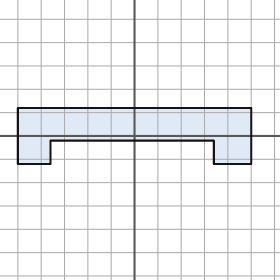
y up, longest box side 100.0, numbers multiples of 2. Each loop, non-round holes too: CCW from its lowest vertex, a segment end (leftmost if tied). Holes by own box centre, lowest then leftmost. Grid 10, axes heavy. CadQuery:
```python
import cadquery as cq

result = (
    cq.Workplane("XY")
    .moveTo(-50.0, -12.0)
    .lineTo(-36.0, -12.0)
    .lineTo(-36.0, -2.0)
    .lineTo(34.0, -2.0)
    .lineTo(34.0, -12.0)
    .lineTo(50.0, -12.0)
    .lineTo(50.0, 12.0)
    .lineTo(-50.0, 12.0)
    .close()
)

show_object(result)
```